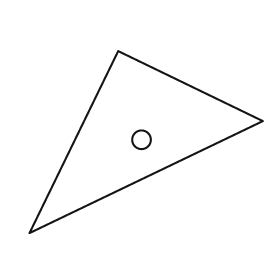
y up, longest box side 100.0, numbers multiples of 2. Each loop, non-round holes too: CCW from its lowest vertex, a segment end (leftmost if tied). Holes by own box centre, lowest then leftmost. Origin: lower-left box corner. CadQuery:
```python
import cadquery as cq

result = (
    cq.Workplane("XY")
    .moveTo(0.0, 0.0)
    .lineTo(100.0, 48.0)
    .lineTo(38.0, 78.0)
    .close()
    .moveTo(48.0, 40.0)
    .circle(4.0)
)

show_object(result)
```